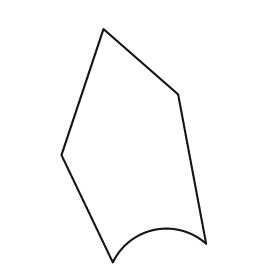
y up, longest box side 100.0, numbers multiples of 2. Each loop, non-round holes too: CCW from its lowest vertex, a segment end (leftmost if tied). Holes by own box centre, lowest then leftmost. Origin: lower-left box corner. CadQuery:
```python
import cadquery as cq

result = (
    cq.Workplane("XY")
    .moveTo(22.0, 0.0)
    .threePointArc((40.0, 14.0), (62.0, 8.0))
    .lineTo(50.0, 72.0)
    .lineTo(18.0, 100.0)
    .lineTo(0.0, 46.0)
    .close()
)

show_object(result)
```